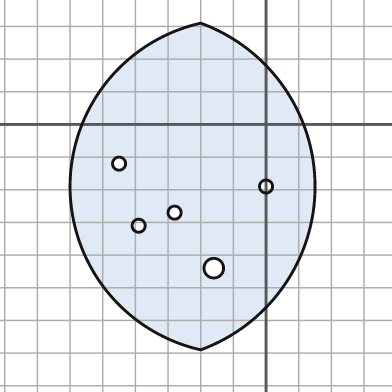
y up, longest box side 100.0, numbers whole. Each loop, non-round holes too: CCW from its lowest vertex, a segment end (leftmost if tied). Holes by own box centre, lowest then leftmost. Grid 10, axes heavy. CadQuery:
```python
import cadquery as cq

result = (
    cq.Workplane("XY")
    .moveTo(-20.0, -69.0)
    .threePointArc((15.0, -19.0), (-20.0, 31.0))
    .threePointArc((-60.0, -19.0), (-20.0, -69.0))
    .close()
    .moveTo(-16.0, -44.0)
    .circle(3.0)
    .moveTo(-39.0, -31.0)
    .circle(2.0)
    .moveTo(-28.0, -27.0)
    .circle(2.0)
    .moveTo(0.0, -19.0)
    .circle(2.0)
    .moveTo(-45.0, -12.0)
    .circle(2.0)
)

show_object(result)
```